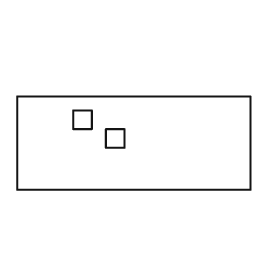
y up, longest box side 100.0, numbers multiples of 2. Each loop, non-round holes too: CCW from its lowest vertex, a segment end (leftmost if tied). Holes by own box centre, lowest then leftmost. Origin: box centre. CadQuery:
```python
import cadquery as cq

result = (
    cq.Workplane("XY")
    .moveTo(-50.0, -20.0)
    .lineTo(50.0, -20.0)
    .lineTo(50.0, 20.0)
    .lineTo(-50.0, 20.0)
    .close()
    .moveTo(-12.0, -2.0)
    .lineTo(-4.0, -2.0)
    .lineTo(-4.0, 6.0)
    .lineTo(-12.0, 6.0)
    .close()
    .moveTo(-26.0, 6.0)
    .lineTo(-18.0, 6.0)
    .lineTo(-18.0, 14.0)
    .lineTo(-26.0, 14.0)
    .close()
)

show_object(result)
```